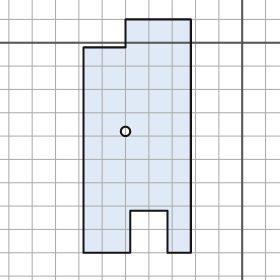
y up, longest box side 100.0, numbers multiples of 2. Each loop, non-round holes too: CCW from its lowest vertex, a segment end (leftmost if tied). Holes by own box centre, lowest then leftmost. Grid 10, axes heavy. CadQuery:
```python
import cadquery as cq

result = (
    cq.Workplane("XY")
    .moveTo(-68.0, -90.0)
    .lineTo(-48.0, -90.0)
    .lineTo(-48.0, -72.0)
    .lineTo(-32.0, -72.0)
    .lineTo(-32.0, -90.0)
    .lineTo(-22.0, -90.0)
    .lineTo(-22.0, 10.0)
    .lineTo(-50.0, 10.0)
    .lineTo(-50.0, -2.0)
    .lineTo(-68.0, -2.0)
    .close()
    .moveTo(-50.0, -38.0)
    .circle(2.0)
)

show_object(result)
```